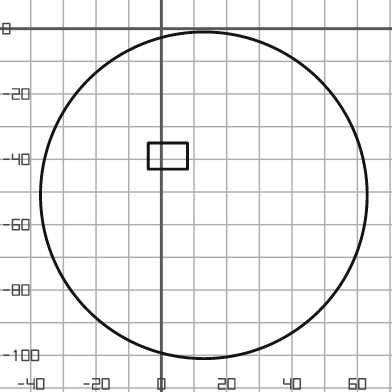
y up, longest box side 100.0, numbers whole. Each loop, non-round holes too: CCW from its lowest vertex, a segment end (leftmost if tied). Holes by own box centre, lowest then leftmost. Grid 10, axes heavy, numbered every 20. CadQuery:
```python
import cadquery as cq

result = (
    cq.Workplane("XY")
    .moveTo(13.0, -51.0)
    .circle(50.0)
    .moveTo(-4.0, -43.0)
    .lineTo(8.0, -43.0)
    .lineTo(8.0, -35.0)
    .lineTo(-4.0, -35.0)
    .close()
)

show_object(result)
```